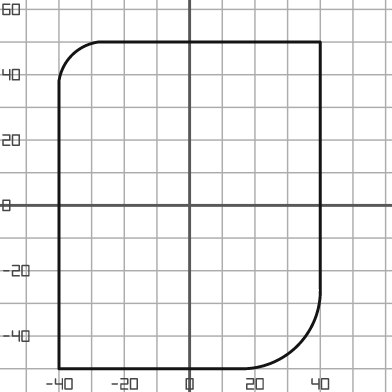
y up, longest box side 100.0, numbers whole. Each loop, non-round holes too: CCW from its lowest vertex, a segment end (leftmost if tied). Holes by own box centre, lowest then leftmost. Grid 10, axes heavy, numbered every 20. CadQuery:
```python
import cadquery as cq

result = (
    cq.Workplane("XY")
    .moveTo(-40.0, -50.0)
    .lineTo(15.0, -50.0)
    .threePointArc((33.0, -43.0), (40.0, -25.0))
    .lineTo(40.0, 50.0)
    .lineTo(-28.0, 50.0)
    .threePointArc((-36.0, 46.0), (-40.0, 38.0))
    .close()
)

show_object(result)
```